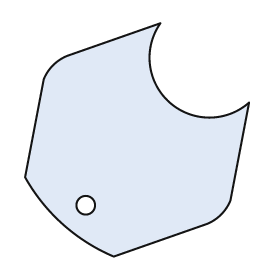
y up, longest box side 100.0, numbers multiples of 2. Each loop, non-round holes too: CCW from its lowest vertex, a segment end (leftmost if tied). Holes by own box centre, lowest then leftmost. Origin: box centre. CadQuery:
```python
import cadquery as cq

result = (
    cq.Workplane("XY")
    .moveTo(-10.0, -50.0)
    .lineTo(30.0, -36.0)
    .threePointArc((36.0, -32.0), (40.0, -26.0))
    .lineTo(48.0, 16.0)
    .threePointArc((14.0, 16.0), (10.0, 50.0))
    .lineTo(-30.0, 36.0)
    .threePointArc((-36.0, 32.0), (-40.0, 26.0))
    .lineTo(-48.0, -16.0)
    .threePointArc((-32.0, -36.0), (-10.0, -50.0))
    .close()
    .moveTo(-22.0, -28.0)
    .circle(4.0)
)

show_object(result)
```